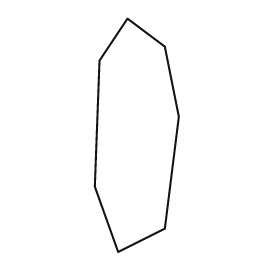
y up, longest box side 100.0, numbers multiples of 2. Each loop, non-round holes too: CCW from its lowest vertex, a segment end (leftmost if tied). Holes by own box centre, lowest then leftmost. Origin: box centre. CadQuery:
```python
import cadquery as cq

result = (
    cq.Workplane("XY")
    .moveTo(-8.0, -50.0)
    .lineTo(12.0, -40.0)
    .lineTo(18.0, 8.0)
    .lineTo(12.0, 38.0)
    .lineTo(-4.0, 50.0)
    .lineTo(-16.0, 32.0)
    .lineTo(-18.0, -22.0)
    .close()
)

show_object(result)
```